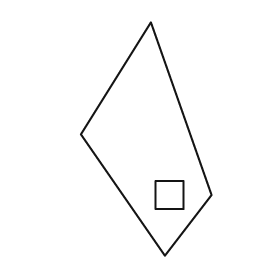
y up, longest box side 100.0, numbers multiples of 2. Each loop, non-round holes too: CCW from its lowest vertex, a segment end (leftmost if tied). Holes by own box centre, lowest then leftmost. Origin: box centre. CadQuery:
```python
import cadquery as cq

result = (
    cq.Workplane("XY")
    .moveTo(8.0, -50.0)
    .lineTo(28.0, -24.0)
    .lineTo(2.0, 50.0)
    .lineTo(-28.0, 2.0)
    .close()
    .moveTo(4.0, -30.0)
    .lineTo(16.0, -30.0)
    .lineTo(16.0, -18.0)
    .lineTo(4.0, -18.0)
    .close()
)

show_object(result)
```